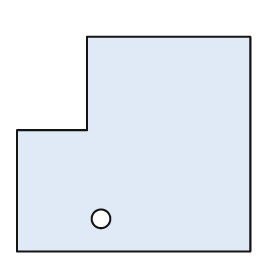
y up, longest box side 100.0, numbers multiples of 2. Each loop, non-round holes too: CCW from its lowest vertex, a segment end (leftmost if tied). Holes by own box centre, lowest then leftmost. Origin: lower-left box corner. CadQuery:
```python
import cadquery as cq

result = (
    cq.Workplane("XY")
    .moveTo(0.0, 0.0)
    .lineTo(100.0, 0.0)
    .lineTo(100.0, 92.0)
    .lineTo(30.0, 92.0)
    .lineTo(30.0, 52.0)
    .lineTo(0.0, 52.0)
    .close()
    .moveTo(36.0, 14.0)
    .circle(4.0)
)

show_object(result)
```